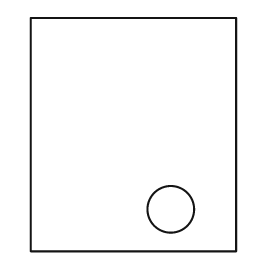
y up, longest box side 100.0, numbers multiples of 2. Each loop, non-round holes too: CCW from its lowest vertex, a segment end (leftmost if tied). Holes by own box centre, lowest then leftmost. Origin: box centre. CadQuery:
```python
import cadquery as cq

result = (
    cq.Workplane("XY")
    .moveTo(-44.0, -50.0)
    .lineTo(44.0, -50.0)
    .lineTo(44.0, 50.0)
    .lineTo(-44.0, 50.0)
    .close()
    .moveTo(16.0, -32.0)
    .circle(10.0)
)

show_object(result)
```